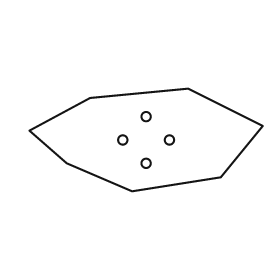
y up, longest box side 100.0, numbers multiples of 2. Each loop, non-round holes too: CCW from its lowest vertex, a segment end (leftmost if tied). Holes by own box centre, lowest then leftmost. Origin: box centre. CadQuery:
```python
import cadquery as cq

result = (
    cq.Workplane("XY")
    .moveTo(-6.0, -22.0)
    .lineTo(32.0, -16.0)
    .lineTo(50.0, 6.0)
    .lineTo(18.0, 22.0)
    .lineTo(-24.0, 18.0)
    .lineTo(-50.0, 4.0)
    .lineTo(-34.0, -10.0)
    .close()
    .moveTo(0.0, -10.0)
    .circle(2.0)
    .moveTo(-10.0, 0.0)
    .circle(2.0)
    .moveTo(10.0, 0.0)
    .circle(2.0)
    .moveTo(0.0, 10.0)
    .circle(2.0)
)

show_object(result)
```